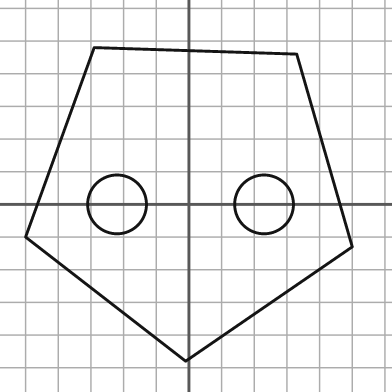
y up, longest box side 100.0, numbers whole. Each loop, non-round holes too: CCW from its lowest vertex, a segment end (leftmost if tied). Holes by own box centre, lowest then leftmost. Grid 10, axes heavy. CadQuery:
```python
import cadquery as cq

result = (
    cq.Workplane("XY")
    .moveTo(-1.0, -48.0)
    .lineTo(50.0, -13.0)
    .lineTo(33.0, 46.0)
    .lineTo(-29.0, 48.0)
    .lineTo(-50.0, -10.0)
    .close()
    .moveTo(-22.0, 0.0)
    .circle(9.0)
    .moveTo(23.0, 0.0)
    .circle(9.0)
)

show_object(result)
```